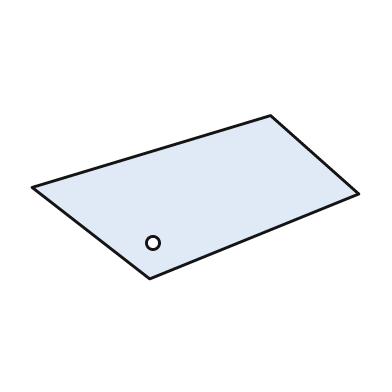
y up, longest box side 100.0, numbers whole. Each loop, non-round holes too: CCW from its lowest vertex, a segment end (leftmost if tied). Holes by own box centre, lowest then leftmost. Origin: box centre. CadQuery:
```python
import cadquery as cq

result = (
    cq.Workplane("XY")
    .moveTo(-14.0, -25.0)
    .lineTo(50.0, 1.0)
    .lineTo(23.0, 25.0)
    .lineTo(-50.0, 3.0)
    .close()
    .moveTo(-13.0, -14.0)
    .circle(2.0)
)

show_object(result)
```